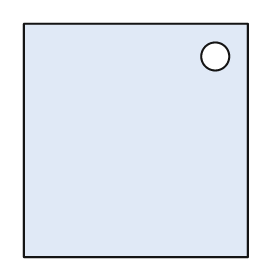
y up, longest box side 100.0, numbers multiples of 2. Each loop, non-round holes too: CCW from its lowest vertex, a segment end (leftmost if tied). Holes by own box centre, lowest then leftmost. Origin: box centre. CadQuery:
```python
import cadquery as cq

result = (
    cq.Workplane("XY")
    .moveTo(-48.0, -50.0)
    .lineTo(48.0, -50.0)
    .lineTo(48.0, 50.0)
    .lineTo(-48.0, 50.0)
    .close()
    .moveTo(34.0, 36.0)
    .circle(6.0)
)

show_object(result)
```